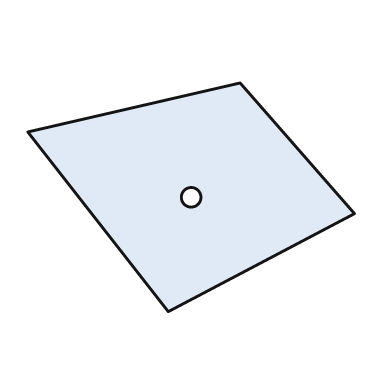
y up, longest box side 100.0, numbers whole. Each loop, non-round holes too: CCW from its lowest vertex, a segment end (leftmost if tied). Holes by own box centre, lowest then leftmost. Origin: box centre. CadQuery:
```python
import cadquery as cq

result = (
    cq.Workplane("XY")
    .moveTo(-7.0, -35.0)
    .lineTo(50.0, -5.0)
    .lineTo(15.0, 35.0)
    .lineTo(-50.0, 20.0)
    .close()
    .moveTo(0.0, 0.0)
    .circle(3.0)
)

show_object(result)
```